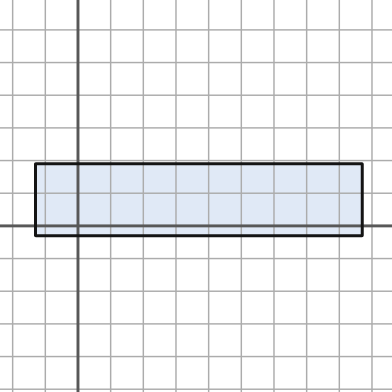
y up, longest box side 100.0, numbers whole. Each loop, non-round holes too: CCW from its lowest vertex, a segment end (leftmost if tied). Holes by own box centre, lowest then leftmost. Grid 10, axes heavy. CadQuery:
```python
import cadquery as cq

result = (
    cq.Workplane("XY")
    .moveTo(-13.0, -3.0)
    .lineTo(87.0, -3.0)
    .lineTo(87.0, 19.0)
    .lineTo(-13.0, 19.0)
    .close()
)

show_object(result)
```